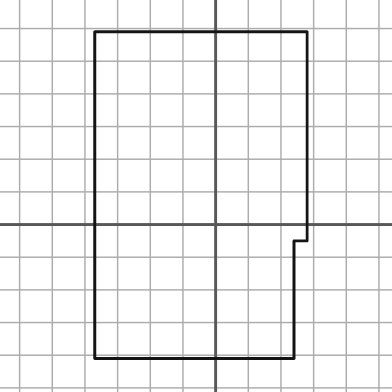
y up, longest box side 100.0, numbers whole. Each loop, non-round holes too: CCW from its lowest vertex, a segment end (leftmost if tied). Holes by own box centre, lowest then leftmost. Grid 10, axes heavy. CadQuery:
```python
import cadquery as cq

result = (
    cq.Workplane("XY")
    .moveTo(-37.0, -41.0)
    .lineTo(24.0, -41.0)
    .lineTo(24.0, -5.0)
    .lineTo(28.0, -5.0)
    .lineTo(28.0, 59.0)
    .lineTo(-37.0, 59.0)
    .close()
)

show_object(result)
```